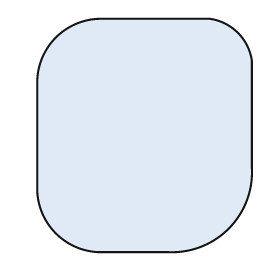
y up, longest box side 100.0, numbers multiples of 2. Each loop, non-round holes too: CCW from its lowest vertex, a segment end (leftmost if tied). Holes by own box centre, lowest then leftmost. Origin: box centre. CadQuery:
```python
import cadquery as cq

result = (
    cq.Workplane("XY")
    .moveTo(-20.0, -50.0)
    .lineTo(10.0, -50.0)
    .threePointArc((36.0, -40.0), (46.0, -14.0))
    .lineTo(46.0, 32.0)
    .threePointArc((40.0, 44.0), (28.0, 50.0))
    .lineTo(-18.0, 50.0)
    .threePointArc((-38.0, 42.0), (-46.0, 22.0))
    .lineTo(-46.0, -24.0)
    .threePointArc((-38.0, -42.0), (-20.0, -50.0))
    .close()
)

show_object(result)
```